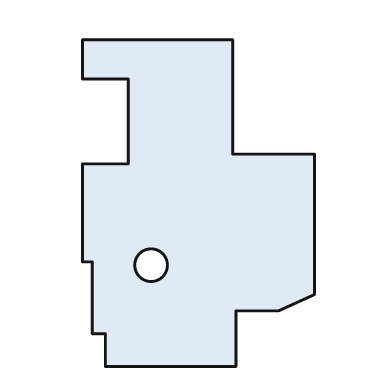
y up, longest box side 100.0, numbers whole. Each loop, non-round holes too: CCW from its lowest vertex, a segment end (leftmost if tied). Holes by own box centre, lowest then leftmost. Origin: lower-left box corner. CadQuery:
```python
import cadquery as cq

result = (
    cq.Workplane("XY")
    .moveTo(7.0, 0.0)
    .lineTo(47.0, 0.0)
    .lineTo(47.0, 17.0)
    .lineTo(60.0, 17.0)
    .lineTo(71.0, 22.0)
    .lineTo(71.0, 65.0)
    .lineTo(46.0, 65.0)
    .lineTo(46.0, 100.0)
    .lineTo(0.0, 100.0)
    .lineTo(0.0, 88.0)
    .lineTo(14.0, 88.0)
    .lineTo(14.0, 62.0)
    .lineTo(0.0, 62.0)
    .lineTo(0.0, 32.0)
    .lineTo(3.0, 32.0)
    .lineTo(3.0, 10.0)
    .lineTo(7.0, 10.0)
    .close()
    .moveTo(21.0, 31.0)
    .circle(5.0)
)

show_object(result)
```